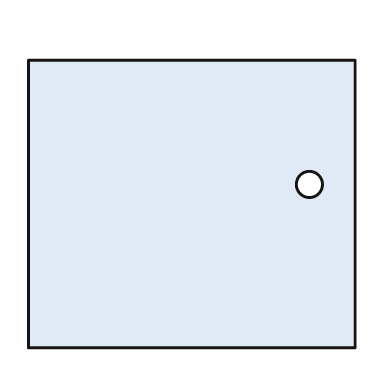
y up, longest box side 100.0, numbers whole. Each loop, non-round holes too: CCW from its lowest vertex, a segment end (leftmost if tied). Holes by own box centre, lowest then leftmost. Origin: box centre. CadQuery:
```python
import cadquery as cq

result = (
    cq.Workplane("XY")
    .moveTo(-50.0, -44.0)
    .lineTo(50.0, -44.0)
    .lineTo(50.0, 44.0)
    .lineTo(-50.0, 44.0)
    .close()
    .moveTo(36.0, 6.0)
    .circle(4.0)
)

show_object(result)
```